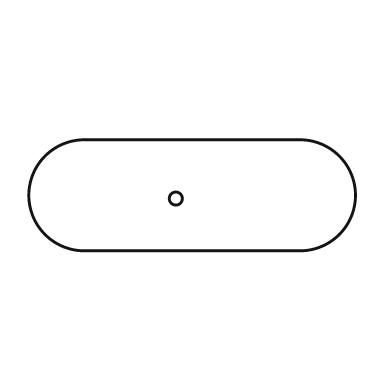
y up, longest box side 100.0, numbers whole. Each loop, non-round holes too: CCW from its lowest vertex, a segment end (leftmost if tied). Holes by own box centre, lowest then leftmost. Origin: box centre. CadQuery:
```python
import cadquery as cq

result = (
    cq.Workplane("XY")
    .moveTo(-33.0, -17.0)
    .lineTo(33.0, -17.0)
    .threePointArc((50.0, 0.0), (33.0, 17.0))
    .lineTo(-33.0, 17.0)
    .threePointArc((-50.0, 0.0), (-33.0, -17.0))
    .close()
    .moveTo(-5.0, -1.0)
    .circle(2.0)
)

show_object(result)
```